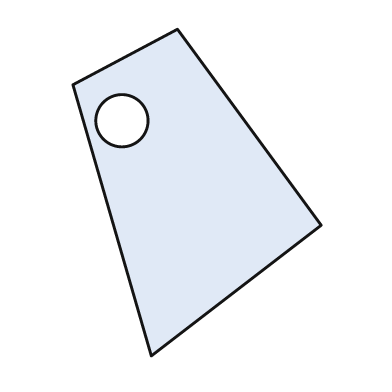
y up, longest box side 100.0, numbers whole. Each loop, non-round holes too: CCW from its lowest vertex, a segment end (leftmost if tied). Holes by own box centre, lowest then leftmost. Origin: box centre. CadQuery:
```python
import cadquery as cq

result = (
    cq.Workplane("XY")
    .moveTo(-14.0, -50.0)
    .lineTo(38.0, -10.0)
    .lineTo(-6.0, 50.0)
    .lineTo(-38.0, 33.0)
    .close()
    .moveTo(-23.0, 22.0)
    .circle(8.0)
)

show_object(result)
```